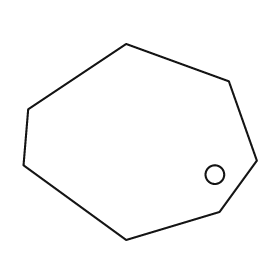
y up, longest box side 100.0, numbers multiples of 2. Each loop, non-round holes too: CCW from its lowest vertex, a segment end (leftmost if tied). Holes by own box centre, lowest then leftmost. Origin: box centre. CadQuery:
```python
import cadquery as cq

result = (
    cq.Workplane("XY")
    .moveTo(-6.0, -42.0)
    .lineTo(34.0, -30.0)
    .lineTo(50.0, -8.0)
    .lineTo(38.0, 26.0)
    .lineTo(-6.0, 42.0)
    .lineTo(-48.0, 14.0)
    .lineTo(-50.0, -10.0)
    .close()
    .moveTo(32.0, -14.0)
    .circle(4.0)
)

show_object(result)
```